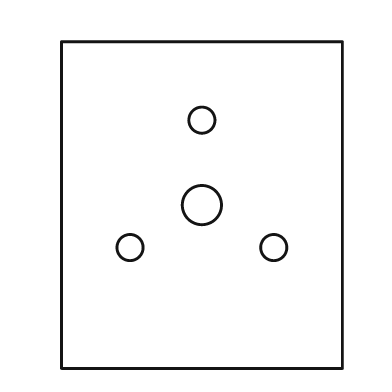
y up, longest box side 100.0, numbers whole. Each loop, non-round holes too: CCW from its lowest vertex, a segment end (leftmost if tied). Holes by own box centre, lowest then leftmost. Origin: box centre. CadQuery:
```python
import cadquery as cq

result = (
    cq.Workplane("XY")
    .moveTo(-43.0, -50.0)
    .lineTo(43.0, -50.0)
    .lineTo(43.0, 50.0)
    .lineTo(-43.0, 50.0)
    .close()
    .moveTo(-22.0, -13.0)
    .circle(4.0)
    .moveTo(22.0, -13.0)
    .circle(4.0)
    .moveTo(0.0, 0.0)
    .circle(6.0)
    .moveTo(0.0, 26.0)
    .circle(4.0)
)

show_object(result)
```